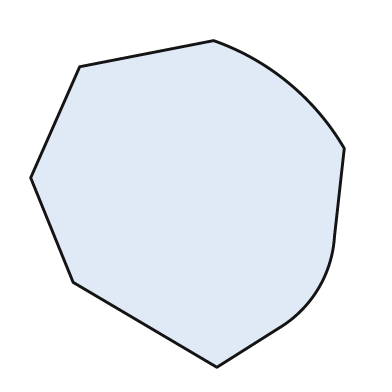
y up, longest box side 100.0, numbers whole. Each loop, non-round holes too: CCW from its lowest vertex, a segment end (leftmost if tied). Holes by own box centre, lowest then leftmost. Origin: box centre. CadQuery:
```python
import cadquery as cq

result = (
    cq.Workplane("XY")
    .moveTo(9.0, -50.0)
    .lineTo(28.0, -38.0)
    .threePointArc((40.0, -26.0), (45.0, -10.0))
    .lineTo(48.0, 17.0)
    .threePointArc((31.0, 37.0), (8.0, 50.0))
    .lineTo(-33.0, 42.0)
    .lineTo(-48.0, 8.0)
    .lineTo(-35.0, -24.0)
    .close()
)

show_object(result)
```